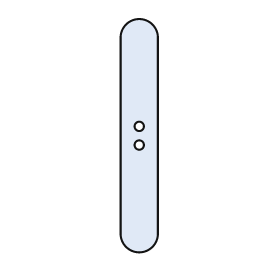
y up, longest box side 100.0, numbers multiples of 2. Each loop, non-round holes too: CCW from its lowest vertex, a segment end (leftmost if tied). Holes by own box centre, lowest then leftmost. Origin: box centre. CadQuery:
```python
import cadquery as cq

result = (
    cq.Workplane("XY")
    .moveTo(-8.0, -42.0)
    .threePointArc((0.0, -50.0), (8.0, -42.0))
    .lineTo(8.0, 42.0)
    .threePointArc((0.0, 50.0), (-8.0, 42.0))
    .close()
    .moveTo(0.0, -4.0)
    .circle(2.0)
    .moveTo(0.0, 4.0)
    .circle(2.0)
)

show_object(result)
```